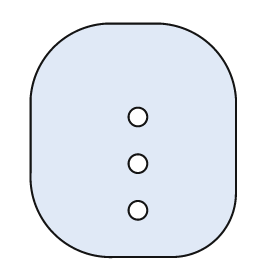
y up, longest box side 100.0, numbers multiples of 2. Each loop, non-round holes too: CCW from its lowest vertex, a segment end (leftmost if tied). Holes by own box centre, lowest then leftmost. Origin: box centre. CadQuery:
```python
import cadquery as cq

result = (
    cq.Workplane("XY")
    .moveTo(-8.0, -50.0)
    .lineTo(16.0, -50.0)
    .threePointArc((36.0, -42.0), (44.0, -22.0))
    .lineTo(44.0, 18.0)
    .threePointArc((34.0, 40.0), (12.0, 50.0))
    .lineTo(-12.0, 50.0)
    .threePointArc((-34.0, 40.0), (-44.0, 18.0))
    .lineTo(-44.0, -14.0)
    .threePointArc((-34.0, -40.0), (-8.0, -50.0))
    .close()
    .moveTo(2.0, -30.0)
    .circle(4.0)
    .moveTo(2.0, -10.0)
    .circle(4.0)
    .moveTo(2.0, 10.0)
    .circle(4.0)
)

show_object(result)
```